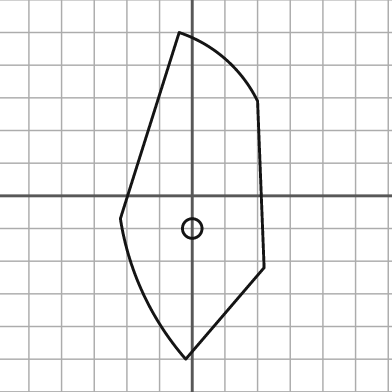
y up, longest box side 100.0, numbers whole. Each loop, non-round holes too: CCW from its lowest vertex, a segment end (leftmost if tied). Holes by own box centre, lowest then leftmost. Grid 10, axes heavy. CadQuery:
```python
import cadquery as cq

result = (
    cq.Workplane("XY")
    .moveTo(-2.0, -50.0)
    .lineTo(22.0, -22.0)
    .lineTo(20.0, 29.0)
    .threePointArc((10.0, 42.0), (-4.0, 50.0))
    .lineTo(-22.0, -7.0)
    .threePointArc((-15.0, -30.0), (-2.0, -50.0))
    .close()
    .moveTo(0.0, -10.0)
    .circle(3.0)
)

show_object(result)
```